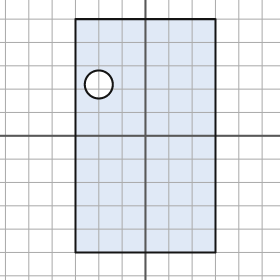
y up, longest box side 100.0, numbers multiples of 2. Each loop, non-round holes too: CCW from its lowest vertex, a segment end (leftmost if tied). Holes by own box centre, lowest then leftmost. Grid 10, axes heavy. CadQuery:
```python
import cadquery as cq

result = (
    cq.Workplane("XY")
    .moveTo(-30.0, -50.0)
    .lineTo(30.0, -50.0)
    .lineTo(30.0, 50.0)
    .lineTo(-30.0, 50.0)
    .close()
    .moveTo(-20.0, 22.0)
    .circle(6.0)
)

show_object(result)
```